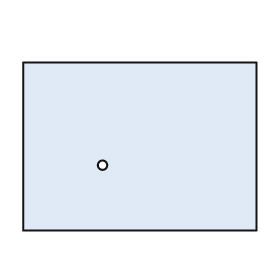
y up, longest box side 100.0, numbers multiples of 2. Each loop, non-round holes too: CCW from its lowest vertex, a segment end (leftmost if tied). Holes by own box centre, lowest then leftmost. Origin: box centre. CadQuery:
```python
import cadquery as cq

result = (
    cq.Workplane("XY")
    .moveTo(-50.0, -36.0)
    .lineTo(50.0, -36.0)
    .lineTo(50.0, 36.0)
    .lineTo(-50.0, 36.0)
    .close()
    .moveTo(-16.0, -8.0)
    .circle(2.0)
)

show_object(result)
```